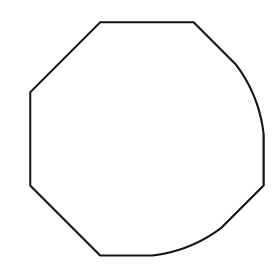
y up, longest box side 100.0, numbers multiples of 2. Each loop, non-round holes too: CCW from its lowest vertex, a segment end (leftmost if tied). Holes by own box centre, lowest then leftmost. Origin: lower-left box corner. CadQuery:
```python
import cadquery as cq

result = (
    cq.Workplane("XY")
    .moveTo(30.0, 0.0)
    .lineTo(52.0, 0.0)
    .threePointArc((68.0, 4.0), (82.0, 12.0))
    .lineTo(100.0, 30.0)
    .lineTo(100.0, 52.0)
    .threePointArc((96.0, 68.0), (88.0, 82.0))
    .lineTo(70.0, 100.0)
    .lineTo(30.0, 100.0)
    .lineTo(0.0, 70.0)
    .lineTo(0.0, 30.0)
    .close()
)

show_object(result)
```